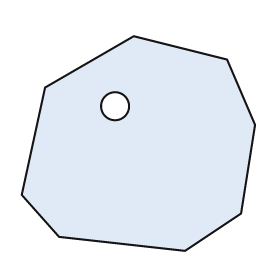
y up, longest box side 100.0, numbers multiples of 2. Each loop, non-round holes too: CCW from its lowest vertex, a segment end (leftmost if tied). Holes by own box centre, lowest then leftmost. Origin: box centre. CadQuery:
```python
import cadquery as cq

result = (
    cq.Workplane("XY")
    .moveTo(20.0, -46.0)
    .lineTo(44.0, -30.0)
    .lineTo(50.0, 8.0)
    .lineTo(38.0, 36.0)
    .lineTo(-2.0, 46.0)
    .lineTo(-40.0, 24.0)
    .lineTo(-50.0, -22.0)
    .lineTo(-34.0, -40.0)
    .close()
    .moveTo(-10.0, 16.0)
    .circle(6.0)
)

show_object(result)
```